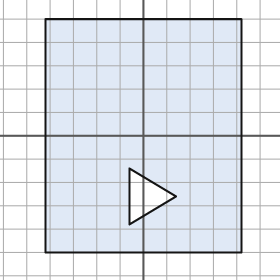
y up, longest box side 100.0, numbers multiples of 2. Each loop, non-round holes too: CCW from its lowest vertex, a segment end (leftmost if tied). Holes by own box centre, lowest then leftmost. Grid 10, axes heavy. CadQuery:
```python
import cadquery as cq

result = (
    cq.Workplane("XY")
    .moveTo(-42.0, -50.0)
    .lineTo(42.0, -50.0)
    .lineTo(42.0, 50.0)
    .lineTo(-42.0, 50.0)
    .close()
    .moveTo(-6.0, -38.0)
    .lineTo(14.0, -26.0)
    .lineTo(-6.0, -14.0)
    .close()
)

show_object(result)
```